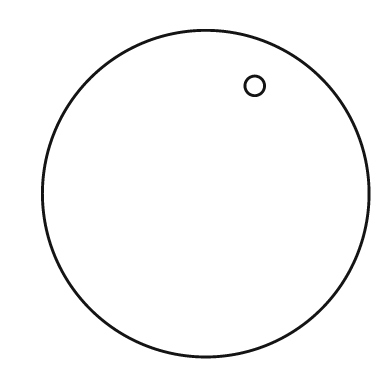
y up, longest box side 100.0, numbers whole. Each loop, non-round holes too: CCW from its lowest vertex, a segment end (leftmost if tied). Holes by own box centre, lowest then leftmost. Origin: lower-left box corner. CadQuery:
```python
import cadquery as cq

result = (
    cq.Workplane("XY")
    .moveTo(50.0, 50.0)
    .circle(50.0)
    .moveTo(65.0, 83.0)
    .circle(3.0)
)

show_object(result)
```